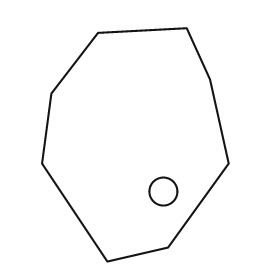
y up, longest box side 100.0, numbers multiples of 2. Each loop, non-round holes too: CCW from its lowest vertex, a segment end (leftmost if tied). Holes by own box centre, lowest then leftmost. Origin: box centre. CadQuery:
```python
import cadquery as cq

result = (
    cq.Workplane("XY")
    .moveTo(-12.0, -50.0)
    .lineTo(14.0, -44.0)
    .lineTo(40.0, -8.0)
    .lineTo(32.0, 28.0)
    .lineTo(22.0, 50.0)
    .lineTo(-16.0, 48.0)
    .lineTo(-36.0, 22.0)
    .lineTo(-40.0, -8.0)
    .close()
    .moveTo(12.0, -20.0)
    .circle(6.0)
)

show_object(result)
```